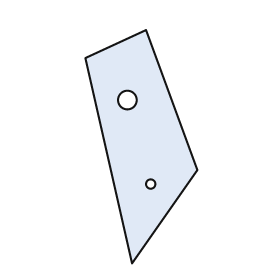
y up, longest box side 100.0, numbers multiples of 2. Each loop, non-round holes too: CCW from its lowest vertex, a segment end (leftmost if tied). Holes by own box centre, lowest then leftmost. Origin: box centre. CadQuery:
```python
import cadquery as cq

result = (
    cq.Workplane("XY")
    .moveTo(-4.0, -50.0)
    .lineTo(24.0, -10.0)
    .lineTo(2.0, 50.0)
    .lineTo(-24.0, 38.0)
    .close()
    .moveTo(4.0, -16.0)
    .circle(2.0)
    .moveTo(-6.0, 20.0)
    .circle(4.0)
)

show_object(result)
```